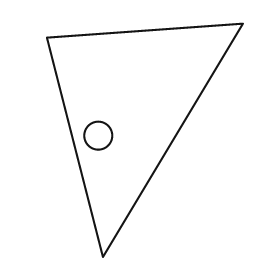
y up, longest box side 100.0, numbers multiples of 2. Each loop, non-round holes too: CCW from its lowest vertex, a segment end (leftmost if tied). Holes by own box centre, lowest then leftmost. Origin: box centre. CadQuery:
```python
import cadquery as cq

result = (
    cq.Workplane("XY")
    .moveTo(-18.0, -50.0)
    .lineTo(42.0, 50.0)
    .lineTo(-42.0, 44.0)
    .close()
    .moveTo(-20.0, 2.0)
    .circle(6.0)
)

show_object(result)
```